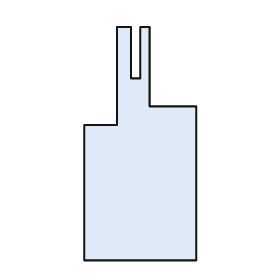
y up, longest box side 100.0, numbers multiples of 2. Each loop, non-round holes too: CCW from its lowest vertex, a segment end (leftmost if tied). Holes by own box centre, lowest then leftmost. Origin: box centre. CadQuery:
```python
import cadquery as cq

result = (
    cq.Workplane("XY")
    .moveTo(-24.0, -50.0)
    .lineTo(24.0, -50.0)
    .lineTo(24.0, 16.0)
    .lineTo(4.0, 16.0)
    .lineTo(4.0, 50.0)
    .lineTo(0.0, 50.0)
    .lineTo(0.0, 28.0)
    .lineTo(-4.0, 28.0)
    .lineTo(-4.0, 50.0)
    .lineTo(-10.0, 50.0)
    .lineTo(-10.0, 8.0)
    .lineTo(-24.0, 8.0)
    .close()
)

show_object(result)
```